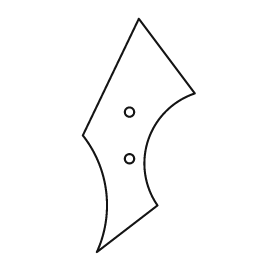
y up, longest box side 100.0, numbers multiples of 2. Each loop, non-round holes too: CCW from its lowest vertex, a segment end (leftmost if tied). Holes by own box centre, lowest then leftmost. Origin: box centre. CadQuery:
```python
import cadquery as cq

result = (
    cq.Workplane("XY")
    .moveTo(-18.0, -50.0)
    .lineTo(8.0, -30.0)
    .threePointArc((4.0, -2.0), (24.0, 18.0))
    .lineTo(0.0, 50.0)
    .lineTo(-24.0, 0.0)
    .threePointArc((-14.0, -24.0), (-18.0, -50.0))
    .close()
    .moveTo(-4.0, -10.0)
    .circle(2.0)
    .moveTo(-4.0, 10.0)
    .circle(2.0)
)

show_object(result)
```